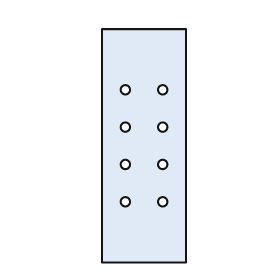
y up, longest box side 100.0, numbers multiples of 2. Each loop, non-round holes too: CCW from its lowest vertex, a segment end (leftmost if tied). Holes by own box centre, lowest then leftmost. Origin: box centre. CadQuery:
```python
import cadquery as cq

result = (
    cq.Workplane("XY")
    .moveTo(-18.0, -50.0)
    .lineTo(18.0, -50.0)
    .lineTo(18.0, 50.0)
    .lineTo(-18.0, 50.0)
    .close()
    .moveTo(-8.0, -24.0)
    .circle(2.0)
    .moveTo(8.0, -24.0)
    .circle(2.0)
    .moveTo(-8.0, -8.0)
    .circle(2.0)
    .moveTo(8.0, -8.0)
    .circle(2.0)
    .moveTo(-8.0, 8.0)
    .circle(2.0)
    .moveTo(8.0, 8.0)
    .circle(2.0)
    .moveTo(-8.0, 24.0)
    .circle(2.0)
    .moveTo(8.0, 24.0)
    .circle(2.0)
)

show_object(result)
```